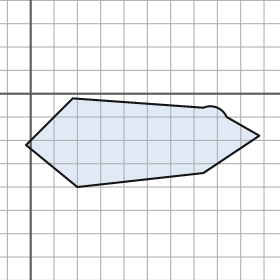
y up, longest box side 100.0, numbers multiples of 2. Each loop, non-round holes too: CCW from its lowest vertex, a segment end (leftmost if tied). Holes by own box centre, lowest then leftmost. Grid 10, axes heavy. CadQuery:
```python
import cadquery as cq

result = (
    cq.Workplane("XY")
    .moveTo(20.0, -40.0)
    .lineTo(74.0, -34.0)
    .lineTo(98.0, -18.0)
    .lineTo(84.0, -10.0)
    .threePointArc((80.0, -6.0), (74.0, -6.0))
    .lineTo(18.0, -2.0)
    .lineTo(-2.0, -22.0)
    .close()
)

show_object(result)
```